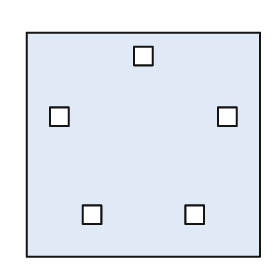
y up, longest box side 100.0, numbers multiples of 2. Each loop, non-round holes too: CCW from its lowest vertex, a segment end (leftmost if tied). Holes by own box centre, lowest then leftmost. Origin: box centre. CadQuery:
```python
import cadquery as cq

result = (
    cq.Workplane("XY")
    .moveTo(-50.0, -48.0)
    .lineTo(50.0, -48.0)
    .lineTo(50.0, 48.0)
    .lineTo(-50.0, 48.0)
    .close()
    .moveTo(-26.0, -34.0)
    .lineTo(-18.0, -34.0)
    .lineTo(-18.0, -26.0)
    .lineTo(-26.0, -26.0)
    .close()
    .moveTo(18.0, -34.0)
    .lineTo(26.0, -34.0)
    .lineTo(26.0, -26.0)
    .lineTo(18.0, -26.0)
    .close()
    .moveTo(-40.0, 8.0)
    .lineTo(-32.0, 8.0)
    .lineTo(-32.0, 16.0)
    .lineTo(-40.0, 16.0)
    .close()
    .moveTo(32.0, 8.0)
    .lineTo(40.0, 8.0)
    .lineTo(40.0, 16.0)
    .lineTo(32.0, 16.0)
    .close()
    .moveTo(-4.0, 34.0)
    .lineTo(4.0, 34.0)
    .lineTo(4.0, 42.0)
    .lineTo(-4.0, 42.0)
    .close()
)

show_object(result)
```